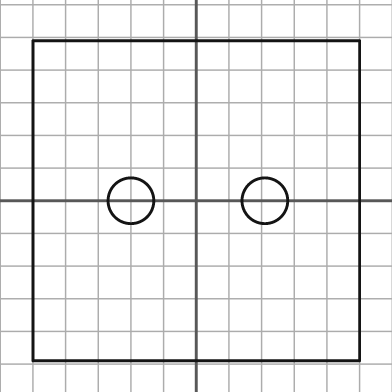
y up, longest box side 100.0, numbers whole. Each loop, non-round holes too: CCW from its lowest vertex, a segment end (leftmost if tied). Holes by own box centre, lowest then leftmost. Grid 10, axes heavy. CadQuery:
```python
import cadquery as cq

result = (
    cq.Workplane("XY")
    .moveTo(-50.0, -49.0)
    .lineTo(50.0, -49.0)
    .lineTo(50.0, 49.0)
    .lineTo(-50.0, 49.0)
    .close()
    .moveTo(-20.0, 0.0)
    .circle(7.0)
    .moveTo(21.0, 0.0)
    .circle(7.0)
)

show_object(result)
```